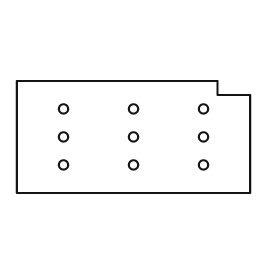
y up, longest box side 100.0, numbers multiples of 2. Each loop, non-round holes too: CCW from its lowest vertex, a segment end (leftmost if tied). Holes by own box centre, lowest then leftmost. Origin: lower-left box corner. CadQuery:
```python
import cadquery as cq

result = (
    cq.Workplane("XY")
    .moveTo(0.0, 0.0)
    .lineTo(100.0, 0.0)
    .lineTo(100.0, 42.0)
    .lineTo(86.0, 42.0)
    .lineTo(86.0, 48.0)
    .lineTo(0.0, 48.0)
    .close()
    .moveTo(20.0, 12.0)
    .circle(2.0)
    .moveTo(50.0, 12.0)
    .circle(2.0)
    .moveTo(80.0, 12.0)
    .circle(2.0)
    .moveTo(20.0, 24.0)
    .circle(2.0)
    .moveTo(50.0, 24.0)
    .circle(2.0)
    .moveTo(80.0, 24.0)
    .circle(2.0)
    .moveTo(20.0, 36.0)
    .circle(2.0)
    .moveTo(50.0, 36.0)
    .circle(2.0)
    .moveTo(80.0, 36.0)
    .circle(2.0)
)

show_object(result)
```